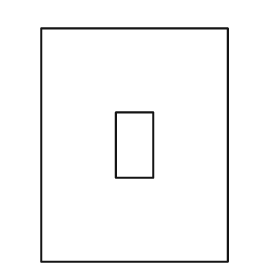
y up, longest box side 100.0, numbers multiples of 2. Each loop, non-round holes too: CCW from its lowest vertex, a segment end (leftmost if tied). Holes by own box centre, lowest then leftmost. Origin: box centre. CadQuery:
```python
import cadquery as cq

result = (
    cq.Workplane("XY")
    .moveTo(-40.0, -50.0)
    .lineTo(40.0, -50.0)
    .lineTo(40.0, 50.0)
    .lineTo(-40.0, 50.0)
    .close()
    .moveTo(-8.0, -14.0)
    .lineTo(8.0, -14.0)
    .lineTo(8.0, 14.0)
    .lineTo(-8.0, 14.0)
    .close()
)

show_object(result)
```